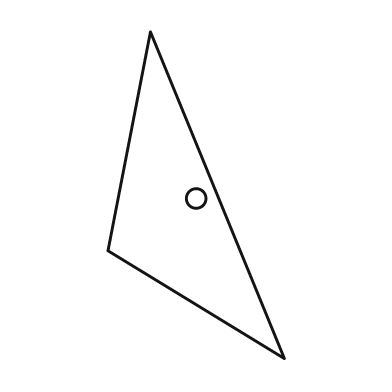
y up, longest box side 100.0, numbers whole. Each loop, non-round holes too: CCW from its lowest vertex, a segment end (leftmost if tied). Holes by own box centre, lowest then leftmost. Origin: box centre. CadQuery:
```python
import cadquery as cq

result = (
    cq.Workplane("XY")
    .moveTo(27.0, -50.0)
    .lineTo(-14.0, 50.0)
    .lineTo(-27.0, -17.0)
    .close()
    .moveTo(0.0, -1.0)
    .circle(3.0)
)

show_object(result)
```